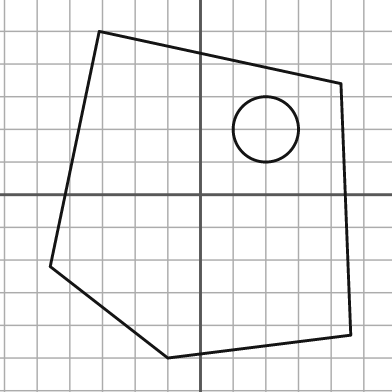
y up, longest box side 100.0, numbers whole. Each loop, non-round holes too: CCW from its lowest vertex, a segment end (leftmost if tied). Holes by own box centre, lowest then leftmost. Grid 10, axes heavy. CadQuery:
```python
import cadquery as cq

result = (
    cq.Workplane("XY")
    .moveTo(-10.0, -50.0)
    .lineTo(46.0, -43.0)
    .lineTo(43.0, 34.0)
    .lineTo(-31.0, 50.0)
    .lineTo(-46.0, -22.0)
    .close()
    .moveTo(20.0, 20.0)
    .circle(10.0)
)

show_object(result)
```